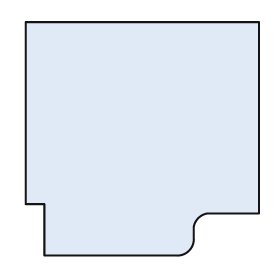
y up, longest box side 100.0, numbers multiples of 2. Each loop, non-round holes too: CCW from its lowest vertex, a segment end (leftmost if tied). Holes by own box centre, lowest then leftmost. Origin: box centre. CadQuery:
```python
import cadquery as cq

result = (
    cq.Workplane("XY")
    .moveTo(-42.0, -50.0)
    .lineTo(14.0, -50.0)
    .threePointArc((20.0, -48.0), (22.0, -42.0))
    .lineTo(22.0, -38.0)
    .threePointArc((24.0, -34.0), (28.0, -32.0))
    .lineTo(50.0, -32.0)
    .lineTo(50.0, 50.0)
    .lineTo(-50.0, 50.0)
    .lineTo(-50.0, -28.0)
    .lineTo(-42.0, -28.0)
    .close()
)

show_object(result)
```